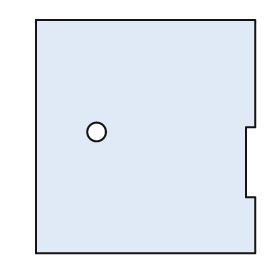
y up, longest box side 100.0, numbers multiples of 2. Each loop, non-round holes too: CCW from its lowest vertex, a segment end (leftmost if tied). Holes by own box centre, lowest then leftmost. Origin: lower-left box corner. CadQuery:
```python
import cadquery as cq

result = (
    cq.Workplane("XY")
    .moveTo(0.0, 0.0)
    .lineTo(94.0, 0.0)
    .lineTo(94.0, 24.0)
    .lineTo(90.0, 24.0)
    .lineTo(90.0, 54.0)
    .lineTo(94.0, 54.0)
    .lineTo(94.0, 100.0)
    .lineTo(0.0, 100.0)
    .close()
    .moveTo(26.0, 52.0)
    .circle(4.0)
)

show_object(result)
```